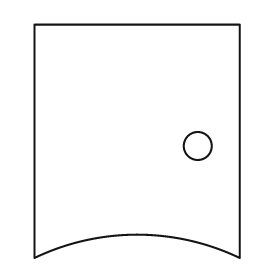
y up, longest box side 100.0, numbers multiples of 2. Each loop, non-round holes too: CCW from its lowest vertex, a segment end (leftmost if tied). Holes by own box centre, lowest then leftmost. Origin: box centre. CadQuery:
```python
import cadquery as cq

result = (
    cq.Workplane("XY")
    .moveTo(-44.0, -50.0)
    .threePointArc((0.0, -40.0), (44.0, -50.0))
    .lineTo(44.0, 50.0)
    .lineTo(-44.0, 50.0)
    .close()
    .moveTo(26.0, -2.0)
    .circle(6.0)
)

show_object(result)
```